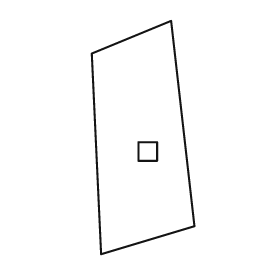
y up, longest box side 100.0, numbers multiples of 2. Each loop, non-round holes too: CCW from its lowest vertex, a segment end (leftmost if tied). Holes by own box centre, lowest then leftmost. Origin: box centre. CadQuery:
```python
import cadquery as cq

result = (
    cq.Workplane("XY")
    .moveTo(-18.0, -50.0)
    .lineTo(22.0, -38.0)
    .lineTo(12.0, 50.0)
    .lineTo(-22.0, 36.0)
    .close()
    .moveTo(-2.0, -10.0)
    .lineTo(6.0, -10.0)
    .lineTo(6.0, -2.0)
    .lineTo(-2.0, -2.0)
    .close()
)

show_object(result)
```